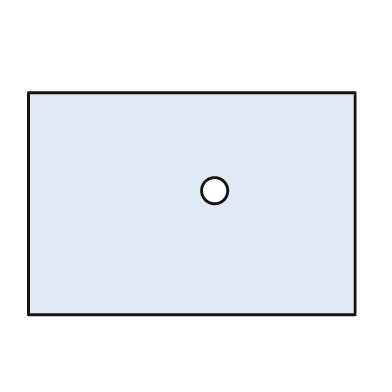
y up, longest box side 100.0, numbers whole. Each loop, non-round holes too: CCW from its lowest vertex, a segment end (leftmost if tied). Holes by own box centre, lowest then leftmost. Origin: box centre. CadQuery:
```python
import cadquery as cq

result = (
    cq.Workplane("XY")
    .moveTo(-50.0, -34.0)
    .lineTo(50.0, -34.0)
    .lineTo(50.0, 34.0)
    .lineTo(-50.0, 34.0)
    .close()
    .moveTo(7.0, 4.0)
    .circle(4.0)
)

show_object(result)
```